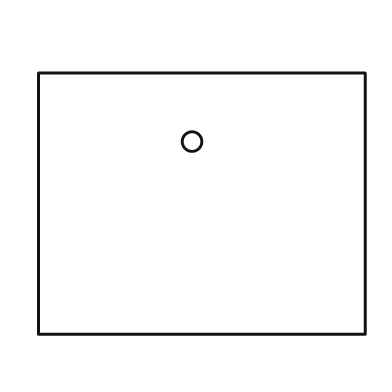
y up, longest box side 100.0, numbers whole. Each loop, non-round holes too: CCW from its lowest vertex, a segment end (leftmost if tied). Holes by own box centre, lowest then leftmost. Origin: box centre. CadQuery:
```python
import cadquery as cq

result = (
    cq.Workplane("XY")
    .moveTo(-50.0, -40.0)
    .lineTo(50.0, -40.0)
    .lineTo(50.0, 40.0)
    .lineTo(-50.0, 40.0)
    .close()
    .moveTo(-3.0, 19.0)
    .circle(3.0)
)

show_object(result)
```